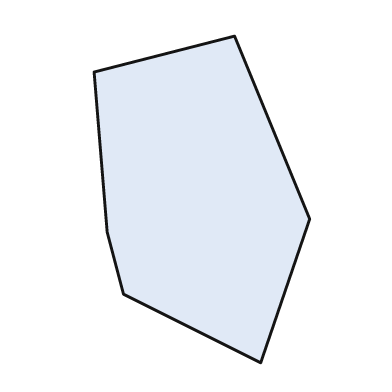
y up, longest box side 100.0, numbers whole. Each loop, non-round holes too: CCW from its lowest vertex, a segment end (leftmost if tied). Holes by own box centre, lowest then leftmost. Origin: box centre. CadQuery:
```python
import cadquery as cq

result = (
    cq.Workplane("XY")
    .moveTo(18.0, -50.0)
    .lineTo(33.0, -6.0)
    .lineTo(10.0, 50.0)
    .lineTo(-33.0, 39.0)
    .lineTo(-29.0, -10.0)
    .lineTo(-24.0, -29.0)
    .close()
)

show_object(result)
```